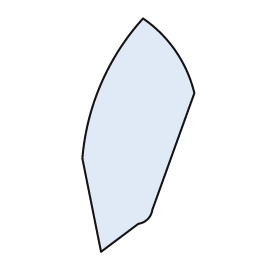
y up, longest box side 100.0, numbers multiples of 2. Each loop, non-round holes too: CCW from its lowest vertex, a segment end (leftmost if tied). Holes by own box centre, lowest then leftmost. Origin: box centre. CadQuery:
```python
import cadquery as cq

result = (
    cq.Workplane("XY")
    .moveTo(-16.0, -50.0)
    .lineTo(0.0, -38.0)
    .threePointArc((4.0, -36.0), (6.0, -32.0))
    .lineTo(24.0, 18.0)
    .threePointArc((16.0, 36.0), (2.0, 50.0))
    .threePointArc((-16.0, 22.0), (-24.0, -10.0))
    .close()
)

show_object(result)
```